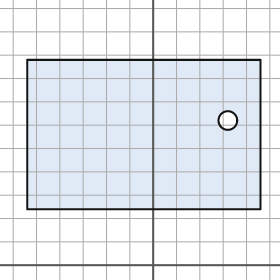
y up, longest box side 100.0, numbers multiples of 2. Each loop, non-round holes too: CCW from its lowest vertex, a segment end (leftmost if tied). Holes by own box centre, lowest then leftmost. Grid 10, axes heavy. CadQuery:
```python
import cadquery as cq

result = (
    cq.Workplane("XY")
    .moveTo(-54.0, 24.0)
    .lineTo(46.0, 24.0)
    .lineTo(46.0, 88.0)
    .lineTo(-54.0, 88.0)
    .close()
    .moveTo(32.0, 62.0)
    .circle(4.0)
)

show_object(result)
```